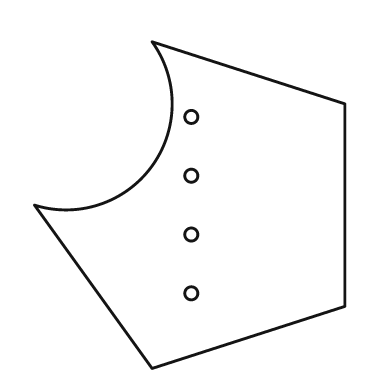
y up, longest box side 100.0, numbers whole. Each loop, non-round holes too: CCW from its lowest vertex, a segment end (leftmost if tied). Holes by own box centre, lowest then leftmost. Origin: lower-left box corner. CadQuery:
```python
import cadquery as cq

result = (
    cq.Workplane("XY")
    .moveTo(36.0, 0.0)
    .lineTo(95.0, 19.0)
    .lineTo(95.0, 81.0)
    .lineTo(36.0, 100.0)
    .threePointArc((36.0, 62.0), (0.0, 50.0))
    .close()
    .moveTo(48.0, 23.0)
    .circle(2.0)
    .moveTo(48.0, 41.0)
    .circle(2.0)
    .moveTo(48.0, 59.0)
    .circle(2.0)
    .moveTo(48.0, 77.0)
    .circle(2.0)
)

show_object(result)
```